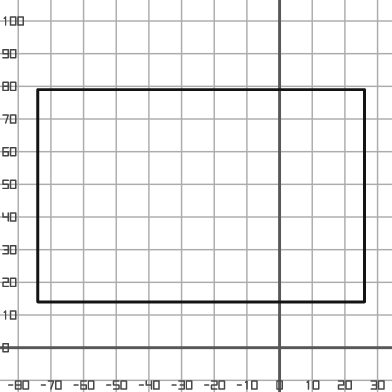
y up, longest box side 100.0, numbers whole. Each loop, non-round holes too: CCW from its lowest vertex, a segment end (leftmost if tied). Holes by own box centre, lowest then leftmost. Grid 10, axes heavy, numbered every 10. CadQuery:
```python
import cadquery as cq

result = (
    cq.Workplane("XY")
    .moveTo(-74.0, 14.0)
    .lineTo(26.0, 14.0)
    .lineTo(26.0, 79.0)
    .lineTo(-74.0, 79.0)
    .close()
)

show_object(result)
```